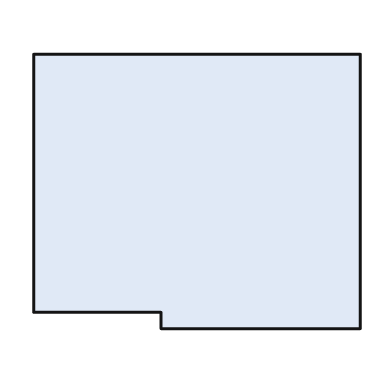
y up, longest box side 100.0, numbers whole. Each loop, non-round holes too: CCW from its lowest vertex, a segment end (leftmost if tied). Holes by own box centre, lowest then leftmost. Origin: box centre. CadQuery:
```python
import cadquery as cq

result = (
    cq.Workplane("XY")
    .moveTo(-11.0, -42.0)
    .lineTo(50.0, -42.0)
    .lineTo(50.0, 42.0)
    .lineTo(-50.0, 42.0)
    .lineTo(-50.0, -37.0)
    .lineTo(-11.0, -37.0)
    .close()
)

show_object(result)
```